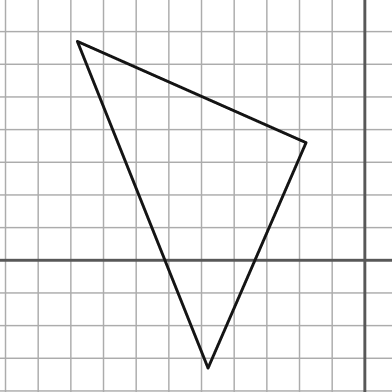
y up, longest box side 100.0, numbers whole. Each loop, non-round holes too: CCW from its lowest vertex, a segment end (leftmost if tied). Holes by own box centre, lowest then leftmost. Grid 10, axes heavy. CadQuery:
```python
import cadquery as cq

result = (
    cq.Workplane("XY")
    .moveTo(-48.0, -33.0)
    .lineTo(-18.0, 36.0)
    .lineTo(-88.0, 67.0)
    .close()
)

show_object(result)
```